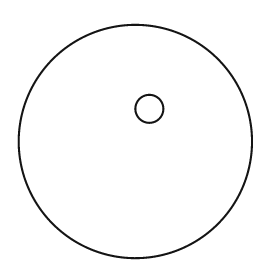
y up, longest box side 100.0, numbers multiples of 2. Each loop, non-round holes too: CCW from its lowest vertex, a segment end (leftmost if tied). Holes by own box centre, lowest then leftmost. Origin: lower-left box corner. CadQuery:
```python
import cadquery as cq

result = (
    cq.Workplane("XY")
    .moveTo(50.0, 50.0)
    .circle(50.0)
    .moveTo(56.0, 64.0)
    .circle(6.0)
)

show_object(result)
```